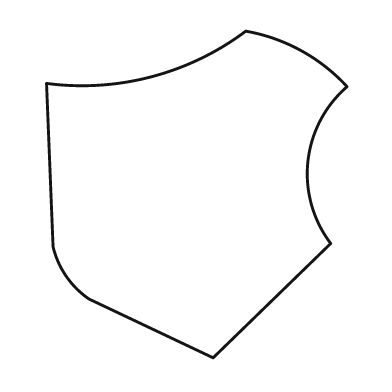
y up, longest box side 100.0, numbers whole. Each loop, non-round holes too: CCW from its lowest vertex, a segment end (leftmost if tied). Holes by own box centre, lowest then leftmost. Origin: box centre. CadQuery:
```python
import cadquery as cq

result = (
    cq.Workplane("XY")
    .moveTo(5.0, -50.0)
    .lineTo(41.0, -15.0)
    .threePointArc((34.0, 10.0), (46.0, 33.0))
    .threePointArc((32.0, 44.0), (15.0, 50.0))
    .threePointArc((-14.0, 36.0), (-46.0, 34.0))
    .lineTo(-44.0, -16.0)
    .threePointArc((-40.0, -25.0), (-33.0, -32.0))
    .close()
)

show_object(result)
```